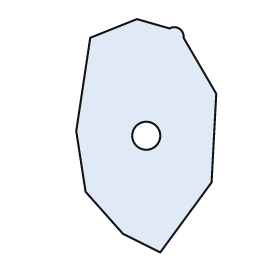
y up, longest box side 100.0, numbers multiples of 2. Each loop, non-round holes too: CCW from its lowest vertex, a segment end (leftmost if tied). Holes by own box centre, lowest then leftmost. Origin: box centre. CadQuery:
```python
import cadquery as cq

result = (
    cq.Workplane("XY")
    .moveTo(6.0, -50.0)
    .lineTo(28.0, -20.0)
    .lineTo(30.0, 18.0)
    .lineTo(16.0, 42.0)
    .threePointArc((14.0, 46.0), (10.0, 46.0))
    .lineTo(-4.0, 50.0)
    .lineTo(-24.0, 42.0)
    .lineTo(-30.0, 2.0)
    .lineTo(-26.0, -24.0)
    .lineTo(-10.0, -42.0)
    .close()
    .moveTo(0.0, 0.0)
    .circle(6.0)
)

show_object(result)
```